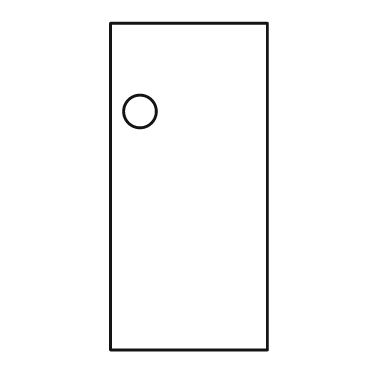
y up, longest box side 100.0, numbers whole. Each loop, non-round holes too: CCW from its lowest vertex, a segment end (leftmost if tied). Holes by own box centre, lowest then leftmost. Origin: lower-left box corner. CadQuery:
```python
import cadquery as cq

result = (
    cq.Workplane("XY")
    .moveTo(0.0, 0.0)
    .lineTo(48.0, 0.0)
    .lineTo(48.0, 100.0)
    .lineTo(0.0, 100.0)
    .close()
    .moveTo(9.0, 73.0)
    .circle(5.0)
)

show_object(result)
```